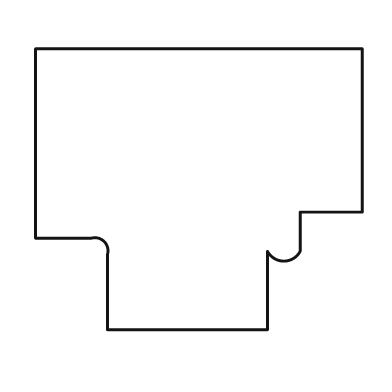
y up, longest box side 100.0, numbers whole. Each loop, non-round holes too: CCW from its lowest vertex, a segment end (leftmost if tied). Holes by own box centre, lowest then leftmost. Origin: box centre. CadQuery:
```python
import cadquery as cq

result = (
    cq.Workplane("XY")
    .moveTo(-28.0, -43.0)
    .lineTo(21.0, -43.0)
    .lineTo(21.0, -19.0)
    .threePointArc((26.0, -22.0), (31.0, -19.0))
    .lineTo(31.0, -7.0)
    .lineTo(50.0, -7.0)
    .lineTo(50.0, 43.0)
    .lineTo(-50.0, 43.0)
    .lineTo(-50.0, -15.0)
    .lineTo(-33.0, -15.0)
    .threePointArc((-29.0, -16.0), (-28.0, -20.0))
    .close()
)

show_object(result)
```